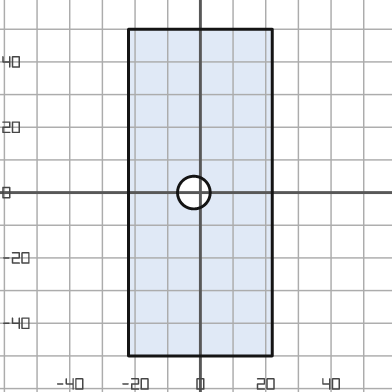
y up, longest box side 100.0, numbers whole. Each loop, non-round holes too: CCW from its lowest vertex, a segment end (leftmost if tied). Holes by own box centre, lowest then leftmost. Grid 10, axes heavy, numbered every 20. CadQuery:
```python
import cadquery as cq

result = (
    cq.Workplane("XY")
    .moveTo(-22.0, -50.0)
    .lineTo(22.0, -50.0)
    .lineTo(22.0, 50.0)
    .lineTo(-22.0, 50.0)
    .close()
    .moveTo(-2.0, 0.0)
    .circle(5.0)
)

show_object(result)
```